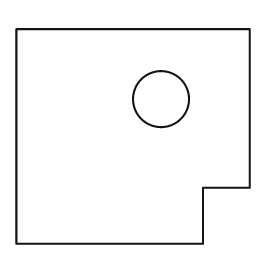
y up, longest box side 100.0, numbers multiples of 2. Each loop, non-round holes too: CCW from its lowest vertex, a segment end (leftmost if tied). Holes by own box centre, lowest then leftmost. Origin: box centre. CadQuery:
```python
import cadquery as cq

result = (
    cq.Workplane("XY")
    .moveTo(-50.0, -46.0)
    .lineTo(30.0, -46.0)
    .lineTo(30.0, -22.0)
    .lineTo(50.0, -22.0)
    .lineTo(50.0, 46.0)
    .lineTo(-50.0, 46.0)
    .close()
    .moveTo(12.0, 16.0)
    .circle(12.0)
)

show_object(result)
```